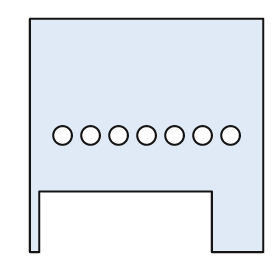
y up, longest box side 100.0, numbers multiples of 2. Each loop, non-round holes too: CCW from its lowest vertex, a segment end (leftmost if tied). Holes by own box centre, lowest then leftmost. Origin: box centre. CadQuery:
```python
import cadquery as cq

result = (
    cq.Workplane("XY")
    .moveTo(-50.0, -50.0)
    .lineTo(-46.0, -50.0)
    .lineTo(-46.0, -24.0)
    .lineTo(28.0, -24.0)
    .lineTo(28.0, -50.0)
    .lineTo(50.0, -50.0)
    .lineTo(50.0, 50.0)
    .lineTo(-50.0, 50.0)
    .close()
    .moveTo(-36.0, 0.0)
    .circle(4.0)
    .moveTo(-24.0, 0.0)
    .circle(4.0)
    .moveTo(-12.0, 0.0)
    .circle(4.0)
    .moveTo(0.0, 0.0)
    .circle(4.0)
    .moveTo(12.0, 0.0)
    .circle(4.0)
    .moveTo(24.0, 0.0)
    .circle(4.0)
    .moveTo(36.0, 0.0)
    .circle(4.0)
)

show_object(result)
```